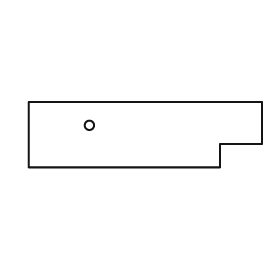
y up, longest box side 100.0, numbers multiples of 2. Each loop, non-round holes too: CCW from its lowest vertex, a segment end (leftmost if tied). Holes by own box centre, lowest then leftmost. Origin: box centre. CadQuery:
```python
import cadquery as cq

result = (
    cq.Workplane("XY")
    .moveTo(-50.0, -14.0)
    .lineTo(32.0, -14.0)
    .lineTo(32.0, -4.0)
    .lineTo(50.0, -4.0)
    .lineTo(50.0, 14.0)
    .lineTo(-50.0, 14.0)
    .close()
    .moveTo(-24.0, 4.0)
    .circle(2.0)
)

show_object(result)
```